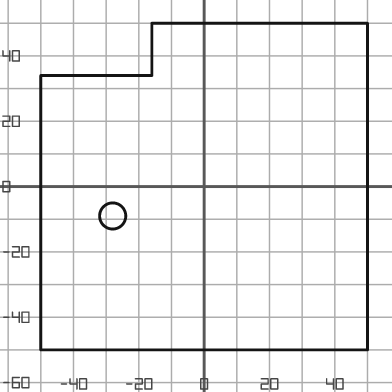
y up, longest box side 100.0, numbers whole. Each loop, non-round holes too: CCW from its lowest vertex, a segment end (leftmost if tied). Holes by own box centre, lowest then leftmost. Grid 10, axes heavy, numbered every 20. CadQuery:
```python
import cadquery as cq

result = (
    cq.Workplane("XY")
    .moveTo(-50.0, -50.0)
    .lineTo(50.0, -50.0)
    .lineTo(50.0, 50.0)
    .lineTo(-16.0, 50.0)
    .lineTo(-16.0, 34.0)
    .lineTo(-50.0, 34.0)
    .close()
    .moveTo(-28.0, -9.0)
    .circle(4.0)
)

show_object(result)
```